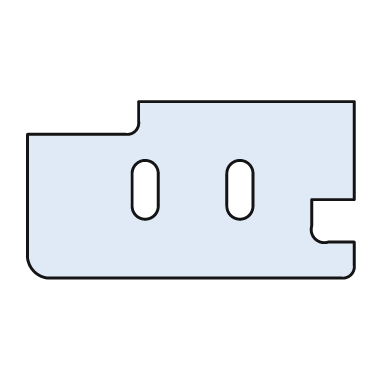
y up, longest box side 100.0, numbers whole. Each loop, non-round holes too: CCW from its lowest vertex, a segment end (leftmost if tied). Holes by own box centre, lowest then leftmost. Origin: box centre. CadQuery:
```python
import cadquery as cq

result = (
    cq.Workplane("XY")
    .moveTo(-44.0, -27.0)
    .lineTo(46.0, -27.0)
    .threePointArc((49.0, -26.0), (50.0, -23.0))
    .lineTo(50.0, -16.0)
    .lineTo(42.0, -16.0)
    .threePointArc((38.0, -15.0), (37.0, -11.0))
    .lineTo(37.0, -3.0)
    .lineTo(50.0, -3.0)
    .lineTo(50.0, 27.0)
    .lineTo(-16.0, 27.0)
    .lineTo(-16.0, 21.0)
    .threePointArc((-17.0, 18.0), (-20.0, 17.0))
    .lineTo(-50.0, 17.0)
    .lineTo(-50.0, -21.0)
    .threePointArc((-48.0, -25.0), (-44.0, -27.0))
    .close()
    .moveTo(-18.0, -5.0)
    .threePointArc((-14.0, -9.0), (-10.0, -5.0))
    .lineTo(-10.0, 5.0)
    .threePointArc((-14.0, 9.0), (-18.0, 5.0))
    .close()
    .moveTo(11.0, -5.0)
    .threePointArc((15.0, -9.0), (19.0, -5.0))
    .lineTo(19.0, 5.0)
    .threePointArc((15.0, 9.0), (11.0, 5.0))
    .close()
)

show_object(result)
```